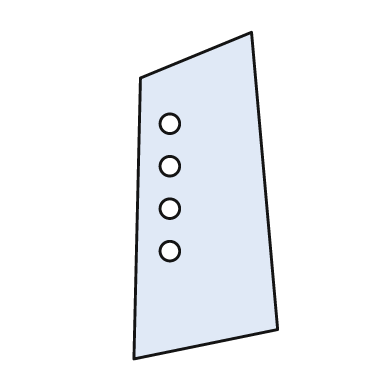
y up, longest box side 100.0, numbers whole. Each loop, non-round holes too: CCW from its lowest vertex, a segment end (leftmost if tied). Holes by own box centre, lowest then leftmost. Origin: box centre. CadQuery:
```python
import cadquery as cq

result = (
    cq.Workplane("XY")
    .moveTo(-22.0, -50.0)
    .lineTo(22.0, -41.0)
    .lineTo(14.0, 50.0)
    .lineTo(-20.0, 36.0)
    .close()
    .moveTo(-11.0, -17.0)
    .circle(3.0)
    .moveTo(-11.0, -4.0)
    .circle(3.0)
    .moveTo(-11.0, 9.0)
    .circle(3.0)
    .moveTo(-11.0, 22.0)
    .circle(3.0)
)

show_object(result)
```